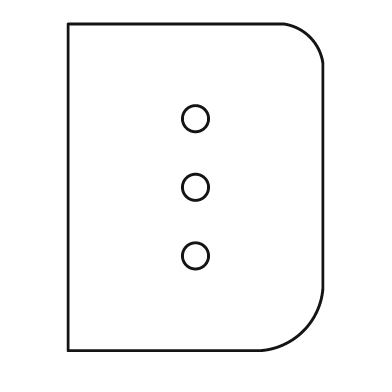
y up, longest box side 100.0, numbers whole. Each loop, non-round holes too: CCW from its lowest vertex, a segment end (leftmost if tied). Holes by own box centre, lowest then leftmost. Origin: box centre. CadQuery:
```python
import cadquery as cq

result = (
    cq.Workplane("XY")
    .moveTo(-39.0, -50.0)
    .lineTo(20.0, -50.0)
    .threePointArc((33.0, -44.0), (39.0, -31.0))
    .lineTo(39.0, 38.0)
    .threePointArc((35.0, 46.0), (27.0, 50.0))
    .lineTo(-39.0, 50.0)
    .close()
    .moveTo(0.0, -21.0)
    .circle(4.0)
    .moveTo(0.0, 0.0)
    .circle(4.0)
    .moveTo(0.0, 21.0)
    .circle(4.0)
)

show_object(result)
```